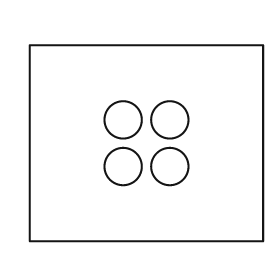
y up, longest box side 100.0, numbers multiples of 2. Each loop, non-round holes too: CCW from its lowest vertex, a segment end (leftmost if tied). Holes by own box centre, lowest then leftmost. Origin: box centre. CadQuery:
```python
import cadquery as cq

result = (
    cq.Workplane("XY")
    .moveTo(-50.0, -42.0)
    .lineTo(50.0, -42.0)
    .lineTo(50.0, 42.0)
    .lineTo(-50.0, 42.0)
    .close()
    .moveTo(-10.0, -10.0)
    .circle(8.0)
    .moveTo(10.0, -10.0)
    .circle(8.0)
    .moveTo(-10.0, 10.0)
    .circle(8.0)
    .moveTo(10.0, 10.0)
    .circle(8.0)
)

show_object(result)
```